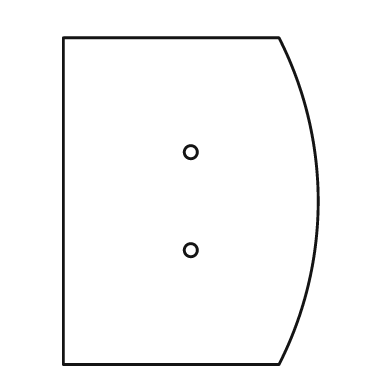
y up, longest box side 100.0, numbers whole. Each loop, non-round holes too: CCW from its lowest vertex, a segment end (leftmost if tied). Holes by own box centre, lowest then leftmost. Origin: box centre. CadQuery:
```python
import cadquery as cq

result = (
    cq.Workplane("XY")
    .moveTo(-39.0, -50.0)
    .lineTo(27.0, -50.0)
    .threePointArc((39.0, 0.0), (27.0, 50.0))
    .lineTo(-39.0, 50.0)
    .close()
    .moveTo(0.0, -15.0)
    .circle(2.0)
    .moveTo(0.0, 15.0)
    .circle(2.0)
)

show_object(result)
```